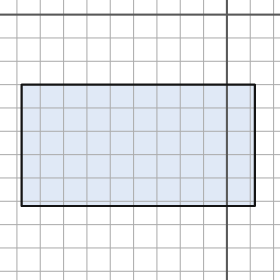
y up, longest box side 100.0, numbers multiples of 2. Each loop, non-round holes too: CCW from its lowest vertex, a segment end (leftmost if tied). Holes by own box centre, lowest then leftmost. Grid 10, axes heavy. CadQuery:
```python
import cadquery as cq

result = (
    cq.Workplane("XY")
    .moveTo(-88.0, -82.0)
    .lineTo(12.0, -82.0)
    .lineTo(12.0, -30.0)
    .lineTo(-88.0, -30.0)
    .close()
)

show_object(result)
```